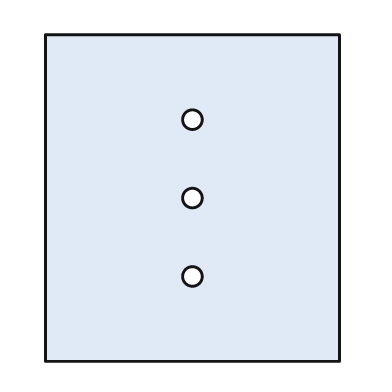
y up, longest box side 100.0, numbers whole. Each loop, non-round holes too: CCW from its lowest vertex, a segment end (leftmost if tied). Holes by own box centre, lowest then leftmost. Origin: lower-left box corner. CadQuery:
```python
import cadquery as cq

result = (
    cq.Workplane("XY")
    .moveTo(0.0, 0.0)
    .lineTo(90.0, 0.0)
    .lineTo(90.0, 100.0)
    .lineTo(0.0, 100.0)
    .close()
    .moveTo(45.0, 26.0)
    .circle(3.0)
    .moveTo(45.0, 50.0)
    .circle(3.0)
    .moveTo(45.0, 74.0)
    .circle(3.0)
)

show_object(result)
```